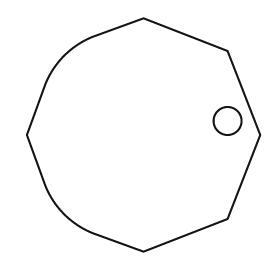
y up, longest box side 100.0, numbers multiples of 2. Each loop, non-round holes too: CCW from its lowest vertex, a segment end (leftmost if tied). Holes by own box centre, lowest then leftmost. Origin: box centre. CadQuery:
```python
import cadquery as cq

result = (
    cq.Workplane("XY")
    .moveTo(0.0, -50.0)
    .lineTo(36.0, -36.0)
    .lineTo(50.0, 0.0)
    .lineTo(36.0, 36.0)
    .lineTo(0.0, 50.0)
    .lineTo(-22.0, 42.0)
    .threePointArc((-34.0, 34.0), (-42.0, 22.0))
    .lineTo(-50.0, 0.0)
    .lineTo(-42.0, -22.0)
    .threePointArc((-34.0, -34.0), (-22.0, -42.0))
    .close()
    .moveTo(36.0, 6.0)
    .circle(6.0)
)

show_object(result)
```